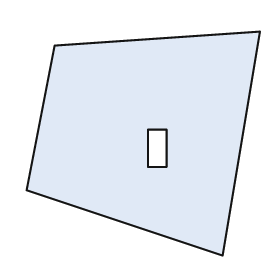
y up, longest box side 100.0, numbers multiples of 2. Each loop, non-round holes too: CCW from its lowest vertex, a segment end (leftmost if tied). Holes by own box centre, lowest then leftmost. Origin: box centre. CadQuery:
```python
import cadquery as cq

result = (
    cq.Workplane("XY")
    .moveTo(34.0, -48.0)
    .lineTo(50.0, 48.0)
    .lineTo(-38.0, 42.0)
    .lineTo(-50.0, -20.0)
    .close()
    .moveTo(2.0, -10.0)
    .lineTo(10.0, -10.0)
    .lineTo(10.0, 6.0)
    .lineTo(2.0, 6.0)
    .close()
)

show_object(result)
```